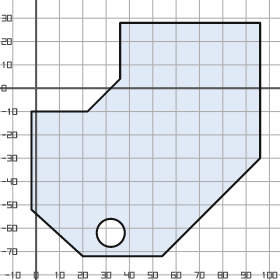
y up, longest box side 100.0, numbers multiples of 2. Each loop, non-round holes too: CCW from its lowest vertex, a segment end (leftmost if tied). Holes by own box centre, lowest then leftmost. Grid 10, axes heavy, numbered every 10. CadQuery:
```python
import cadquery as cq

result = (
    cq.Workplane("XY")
    .moveTo(20.0, -72.0)
    .lineTo(54.0, -72.0)
    .lineTo(96.0, -30.0)
    .lineTo(96.0, 28.0)
    .lineTo(36.0, 28.0)
    .lineTo(36.0, 4.0)
    .lineTo(22.0, -10.0)
    .lineTo(-2.0, -10.0)
    .lineTo(-2.0, -52.0)
    .close()
    .moveTo(32.0, -62.0)
    .circle(6.0)
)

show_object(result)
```